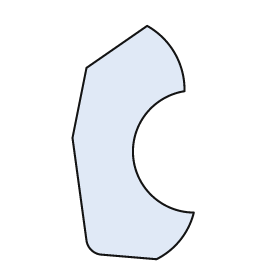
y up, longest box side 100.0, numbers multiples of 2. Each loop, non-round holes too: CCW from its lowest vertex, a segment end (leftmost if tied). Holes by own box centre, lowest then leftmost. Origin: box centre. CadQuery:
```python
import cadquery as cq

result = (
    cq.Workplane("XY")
    .moveTo(10.0, -50.0)
    .threePointArc((20.0, -42.0), (26.0, -30.0))
    .threePointArc((0.0, -6.0), (22.0, 22.0))
    .threePointArc((18.0, 38.0), (6.0, 50.0))
    .lineTo(-20.0, 32.0)
    .lineTo(-26.0, 2.0)
    .lineTo(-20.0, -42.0)
    .threePointArc((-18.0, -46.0), (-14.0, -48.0))
    .close()
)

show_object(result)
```